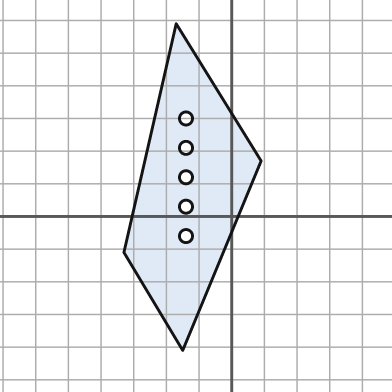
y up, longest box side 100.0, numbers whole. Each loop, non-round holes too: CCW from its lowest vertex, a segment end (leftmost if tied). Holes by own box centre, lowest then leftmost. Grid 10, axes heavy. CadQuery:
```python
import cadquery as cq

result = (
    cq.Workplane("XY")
    .moveTo(-15.0, -41.0)
    .lineTo(9.0, 17.0)
    .lineTo(-17.0, 59.0)
    .lineTo(-33.0, -11.0)
    .close()
    .moveTo(-14.0, -6.0)
    .circle(2.0)
    .moveTo(-14.0, 3.0)
    .circle(2.0)
    .moveTo(-14.0, 12.0)
    .circle(2.0)
    .moveTo(-14.0, 21.0)
    .circle(2.0)
    .moveTo(-14.0, 30.0)
    .circle(2.0)
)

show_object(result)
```